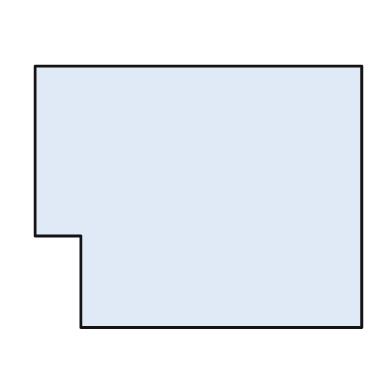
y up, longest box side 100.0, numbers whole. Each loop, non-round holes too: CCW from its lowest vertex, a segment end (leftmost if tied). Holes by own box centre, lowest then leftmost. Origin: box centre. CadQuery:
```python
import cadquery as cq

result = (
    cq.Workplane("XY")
    .moveTo(-36.0, -40.0)
    .lineTo(50.0, -40.0)
    .lineTo(50.0, 40.0)
    .lineTo(-50.0, 40.0)
    .lineTo(-50.0, -12.0)
    .lineTo(-36.0, -12.0)
    .close()
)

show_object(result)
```